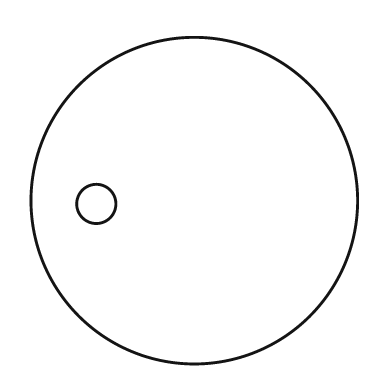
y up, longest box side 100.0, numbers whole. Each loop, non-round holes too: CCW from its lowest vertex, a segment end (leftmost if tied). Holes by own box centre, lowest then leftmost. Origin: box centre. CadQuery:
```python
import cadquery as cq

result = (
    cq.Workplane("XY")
    .moveTo(0.0, 0.0)
    .circle(50.0)
    .moveTo(-30.0, -1.0)
    .circle(6.0)
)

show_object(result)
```